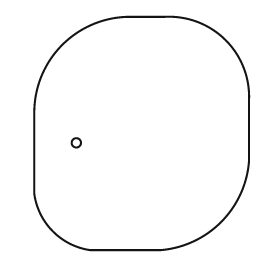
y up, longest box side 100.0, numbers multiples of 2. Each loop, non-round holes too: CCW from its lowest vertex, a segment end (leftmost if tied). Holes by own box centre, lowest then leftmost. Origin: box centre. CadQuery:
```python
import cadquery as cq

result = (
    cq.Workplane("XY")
    .moveTo(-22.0, -50.0)
    .lineTo(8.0, -50.0)
    .threePointArc((34.0, -38.0), (46.0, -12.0))
    .lineTo(46.0, 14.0)
    .threePointArc((36.0, 40.0), (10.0, 50.0))
    .lineTo(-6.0, 50.0)
    .threePointArc((-34.0, 38.0), (-46.0, 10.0))
    .lineTo(-46.0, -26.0)
    .threePointArc((-38.0, -42.0), (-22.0, -50.0))
    .close()
    .moveTo(-28.0, -4.0)
    .circle(2.0)
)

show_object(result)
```